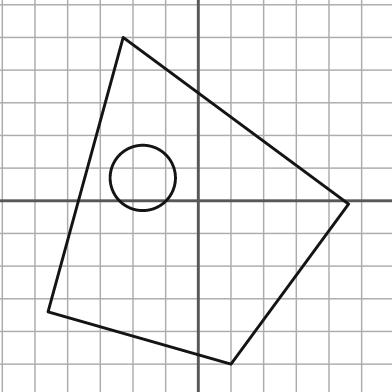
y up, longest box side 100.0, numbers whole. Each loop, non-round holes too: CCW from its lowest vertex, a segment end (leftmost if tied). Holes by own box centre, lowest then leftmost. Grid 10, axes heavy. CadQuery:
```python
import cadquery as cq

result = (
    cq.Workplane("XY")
    .moveTo(10.0, -50.0)
    .lineTo(46.0, -1.0)
    .lineTo(-23.0, 50.0)
    .lineTo(-46.0, -34.0)
    .close()
    .moveTo(-17.0, 7.0)
    .circle(10.0)
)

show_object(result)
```